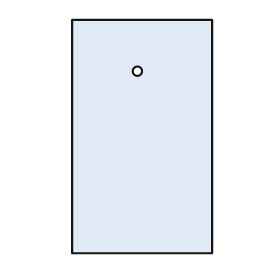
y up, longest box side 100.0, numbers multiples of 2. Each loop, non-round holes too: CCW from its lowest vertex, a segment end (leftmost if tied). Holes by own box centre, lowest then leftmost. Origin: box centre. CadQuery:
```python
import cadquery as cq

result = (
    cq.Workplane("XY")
    .moveTo(-30.0, -50.0)
    .lineTo(30.0, -50.0)
    .lineTo(30.0, 50.0)
    .lineTo(-30.0, 50.0)
    .close()
    .moveTo(-2.0, 28.0)
    .circle(2.0)
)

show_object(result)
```